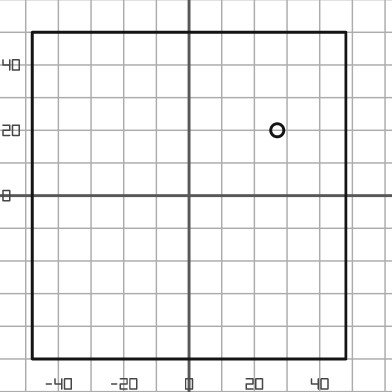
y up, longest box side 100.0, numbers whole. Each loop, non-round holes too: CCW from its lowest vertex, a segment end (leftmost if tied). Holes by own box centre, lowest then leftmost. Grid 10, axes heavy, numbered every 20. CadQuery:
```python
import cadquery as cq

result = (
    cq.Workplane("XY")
    .moveTo(-48.0, -50.0)
    .lineTo(48.0, -50.0)
    .lineTo(48.0, 50.0)
    .lineTo(-48.0, 50.0)
    .close()
    .moveTo(27.0, 20.0)
    .circle(2.0)
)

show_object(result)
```